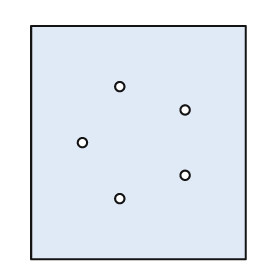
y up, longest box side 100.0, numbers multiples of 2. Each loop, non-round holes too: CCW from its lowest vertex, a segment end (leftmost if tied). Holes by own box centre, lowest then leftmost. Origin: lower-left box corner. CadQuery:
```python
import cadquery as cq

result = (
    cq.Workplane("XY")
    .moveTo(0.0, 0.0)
    .lineTo(92.0, 0.0)
    .lineTo(92.0, 100.0)
    .lineTo(0.0, 100.0)
    .close()
    .moveTo(38.0, 26.0)
    .circle(2.0)
    .moveTo(66.0, 36.0)
    .circle(2.0)
    .moveTo(22.0, 50.0)
    .circle(2.0)
    .moveTo(66.0, 64.0)
    .circle(2.0)
    .moveTo(38.0, 74.0)
    .circle(2.0)
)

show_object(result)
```